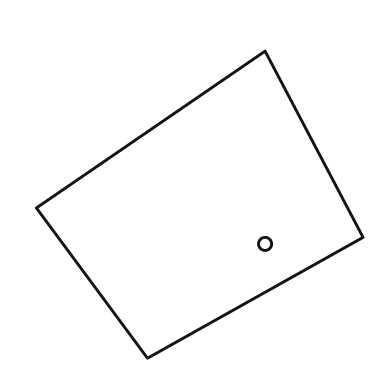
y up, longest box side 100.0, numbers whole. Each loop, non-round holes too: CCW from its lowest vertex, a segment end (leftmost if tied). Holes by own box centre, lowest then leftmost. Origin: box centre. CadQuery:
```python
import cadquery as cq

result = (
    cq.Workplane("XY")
    .moveTo(-16.0, -47.0)
    .lineTo(50.0, -10.0)
    .lineTo(20.0, 47.0)
    .lineTo(-50.0, -1.0)
    .close()
    .moveTo(20.0, -12.0)
    .circle(2.0)
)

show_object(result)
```